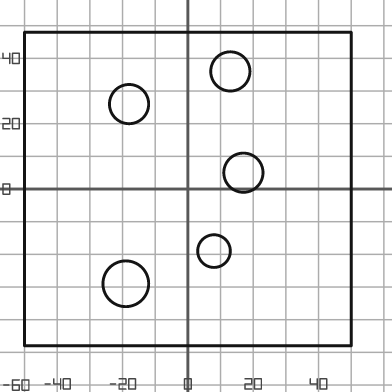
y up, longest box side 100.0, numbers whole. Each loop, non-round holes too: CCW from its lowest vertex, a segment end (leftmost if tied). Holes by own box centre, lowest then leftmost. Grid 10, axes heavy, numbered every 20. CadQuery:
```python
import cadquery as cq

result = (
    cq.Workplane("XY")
    .moveTo(-50.0, -48.0)
    .lineTo(50.0, -48.0)
    .lineTo(50.0, 48.0)
    .lineTo(-50.0, 48.0)
    .close()
    .moveTo(-19.0, -29.0)
    .circle(7.0)
    .moveTo(8.0, -19.0)
    .circle(5.0)
    .moveTo(17.0, 5.0)
    .circle(6.0)
    .moveTo(-18.0, 26.0)
    .circle(6.0)
    .moveTo(13.0, 36.0)
    .circle(6.0)
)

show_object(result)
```